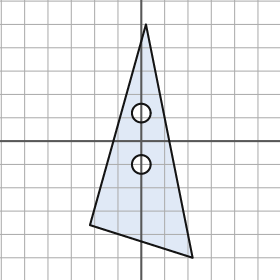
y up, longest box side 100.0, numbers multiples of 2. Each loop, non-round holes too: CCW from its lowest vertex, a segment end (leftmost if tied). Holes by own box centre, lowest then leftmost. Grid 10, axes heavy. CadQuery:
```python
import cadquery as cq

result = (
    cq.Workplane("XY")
    .moveTo(22.0, -50.0)
    .lineTo(2.0, 50.0)
    .lineTo(-22.0, -36.0)
    .close()
    .moveTo(0.0, -10.0)
    .circle(4.0)
    .moveTo(0.0, 12.0)
    .circle(4.0)
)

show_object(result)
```